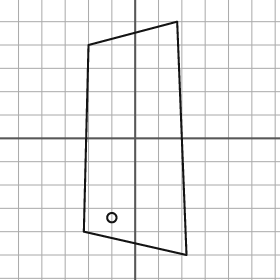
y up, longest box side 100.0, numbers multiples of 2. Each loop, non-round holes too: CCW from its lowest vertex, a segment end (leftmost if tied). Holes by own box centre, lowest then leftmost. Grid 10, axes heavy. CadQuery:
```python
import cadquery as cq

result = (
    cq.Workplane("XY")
    .moveTo(22.0, -50.0)
    .lineTo(18.0, 50.0)
    .lineTo(-20.0, 40.0)
    .lineTo(-22.0, -40.0)
    .close()
    .moveTo(-10.0, -34.0)
    .circle(2.0)
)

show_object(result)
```